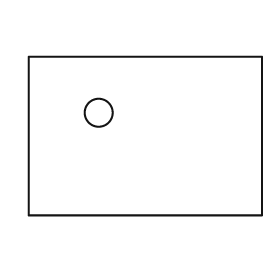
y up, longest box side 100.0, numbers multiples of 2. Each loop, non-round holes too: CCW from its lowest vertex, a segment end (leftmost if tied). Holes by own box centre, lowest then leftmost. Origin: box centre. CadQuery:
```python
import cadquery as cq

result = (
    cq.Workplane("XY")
    .moveTo(-50.0, -34.0)
    .lineTo(50.0, -34.0)
    .lineTo(50.0, 34.0)
    .lineTo(-50.0, 34.0)
    .close()
    .moveTo(-20.0, 10.0)
    .circle(6.0)
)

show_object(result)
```